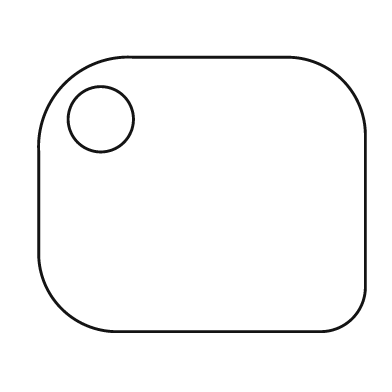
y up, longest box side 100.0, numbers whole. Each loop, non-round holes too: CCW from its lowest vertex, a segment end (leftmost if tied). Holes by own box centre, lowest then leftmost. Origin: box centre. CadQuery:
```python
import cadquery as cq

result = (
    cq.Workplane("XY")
    .moveTo(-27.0, -42.0)
    .lineTo(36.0, -42.0)
    .threePointArc((46.0, -38.0), (50.0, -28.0))
    .lineTo(50.0, 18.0)
    .threePointArc((43.0, 35.0), (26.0, 42.0))
    .lineTo(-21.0, 42.0)
    .threePointArc((-42.0, 34.0), (-50.0, 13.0))
    .lineTo(-50.0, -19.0)
    .threePointArc((-43.0, -35.0), (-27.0, -42.0))
    .close()
    .moveTo(-31.0, 23.0)
    .circle(10.0)
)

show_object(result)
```